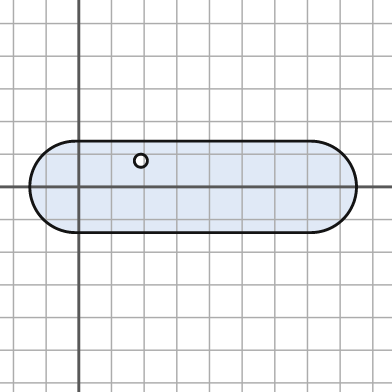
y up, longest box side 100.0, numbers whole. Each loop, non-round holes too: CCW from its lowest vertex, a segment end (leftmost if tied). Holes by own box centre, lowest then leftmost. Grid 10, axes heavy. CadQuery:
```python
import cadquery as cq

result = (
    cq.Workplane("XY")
    .moveTo(-1.0, -14.0)
    .lineTo(71.0, -14.0)
    .threePointArc((85.0, 0.0), (71.0, 14.0))
    .lineTo(-1.0, 14.0)
    .threePointArc((-15.0, 0.0), (-1.0, -14.0))
    .close()
    .moveTo(19.0, 8.0)
    .circle(2.0)
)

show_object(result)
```